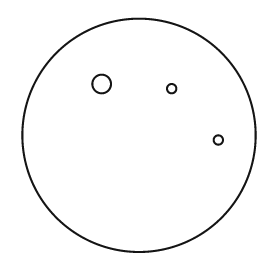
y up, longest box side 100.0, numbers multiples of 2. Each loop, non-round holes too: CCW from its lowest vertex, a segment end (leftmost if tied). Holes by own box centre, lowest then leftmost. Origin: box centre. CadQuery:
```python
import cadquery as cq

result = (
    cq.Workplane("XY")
    .moveTo(0.0, 0.0)
    .circle(50.0)
    .moveTo(34.0, -2.0)
    .circle(2.0)
    .moveTo(14.0, 20.0)
    .circle(2.0)
    .moveTo(-16.0, 22.0)
    .circle(4.0)
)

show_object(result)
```